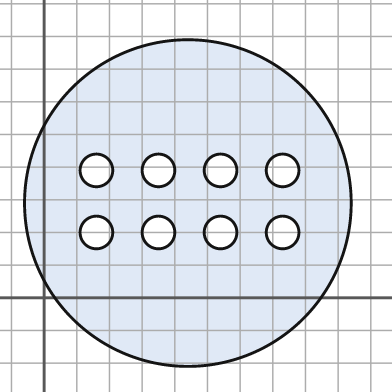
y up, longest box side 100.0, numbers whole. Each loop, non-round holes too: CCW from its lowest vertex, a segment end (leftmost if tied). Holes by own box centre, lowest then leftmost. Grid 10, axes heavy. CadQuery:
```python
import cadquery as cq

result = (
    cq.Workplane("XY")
    .moveTo(44.0, 29.0)
    .circle(50.0)
    .moveTo(16.0, 20.0)
    .circle(5.0)
    .moveTo(35.0, 20.0)
    .circle(5.0)
    .moveTo(54.0, 20.0)
    .circle(5.0)
    .moveTo(73.0, 20.0)
    .circle(5.0)
    .moveTo(16.0, 39.0)
    .circle(5.0)
    .moveTo(35.0, 39.0)
    .circle(5.0)
    .moveTo(54.0, 39.0)
    .circle(5.0)
    .moveTo(73.0, 39.0)
    .circle(5.0)
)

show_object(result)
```